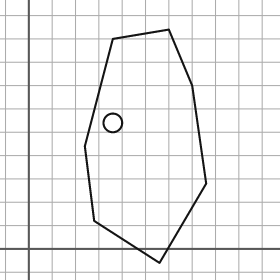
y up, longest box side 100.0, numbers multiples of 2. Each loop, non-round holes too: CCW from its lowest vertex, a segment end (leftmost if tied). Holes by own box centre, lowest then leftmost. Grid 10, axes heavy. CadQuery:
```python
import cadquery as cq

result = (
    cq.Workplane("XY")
    .moveTo(56.0, -6.0)
    .lineTo(76.0, 28.0)
    .lineTo(70.0, 70.0)
    .lineTo(60.0, 94.0)
    .lineTo(36.0, 90.0)
    .lineTo(24.0, 44.0)
    .lineTo(28.0, 12.0)
    .close()
    .moveTo(36.0, 54.0)
    .circle(4.0)
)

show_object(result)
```